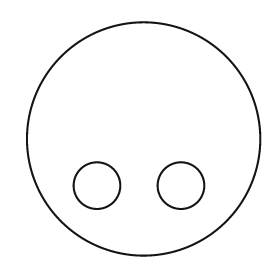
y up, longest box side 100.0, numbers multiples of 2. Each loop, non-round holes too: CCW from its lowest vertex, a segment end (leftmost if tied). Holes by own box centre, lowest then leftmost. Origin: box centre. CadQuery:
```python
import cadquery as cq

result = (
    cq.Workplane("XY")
    .moveTo(0.0, 0.0)
    .circle(50.0)
    .moveTo(-20.0, -20.0)
    .circle(10.0)
    .moveTo(16.0, -20.0)
    .circle(10.0)
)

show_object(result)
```